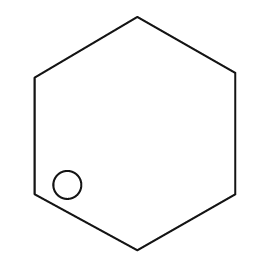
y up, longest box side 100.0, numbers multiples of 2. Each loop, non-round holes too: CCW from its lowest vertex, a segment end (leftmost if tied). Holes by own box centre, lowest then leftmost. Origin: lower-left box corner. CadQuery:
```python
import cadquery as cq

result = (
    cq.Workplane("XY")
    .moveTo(44.0, 0.0)
    .lineTo(86.0, 24.0)
    .lineTo(86.0, 76.0)
    .lineTo(44.0, 100.0)
    .lineTo(0.0, 74.0)
    .lineTo(0.0, 24.0)
    .close()
    .moveTo(14.0, 28.0)
    .circle(6.0)
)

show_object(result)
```